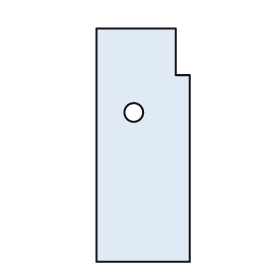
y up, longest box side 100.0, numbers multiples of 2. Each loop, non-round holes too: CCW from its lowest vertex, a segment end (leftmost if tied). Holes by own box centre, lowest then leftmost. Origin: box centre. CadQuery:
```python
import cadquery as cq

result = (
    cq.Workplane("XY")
    .moveTo(-20.0, -50.0)
    .lineTo(20.0, -50.0)
    .lineTo(20.0, 30.0)
    .lineTo(14.0, 30.0)
    .lineTo(14.0, 50.0)
    .lineTo(-20.0, 50.0)
    .close()
    .moveTo(-4.0, 14.0)
    .circle(4.0)
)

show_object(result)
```